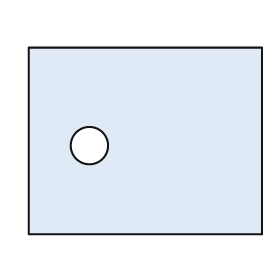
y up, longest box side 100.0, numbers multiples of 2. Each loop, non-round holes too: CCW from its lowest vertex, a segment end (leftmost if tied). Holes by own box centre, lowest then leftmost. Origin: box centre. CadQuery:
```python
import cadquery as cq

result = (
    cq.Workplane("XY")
    .moveTo(-50.0, -40.0)
    .lineTo(50.0, -40.0)
    .lineTo(50.0, 40.0)
    .lineTo(-50.0, 40.0)
    .close()
    .moveTo(-24.0, -2.0)
    .circle(8.0)
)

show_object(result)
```